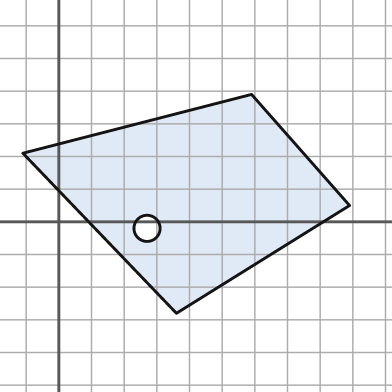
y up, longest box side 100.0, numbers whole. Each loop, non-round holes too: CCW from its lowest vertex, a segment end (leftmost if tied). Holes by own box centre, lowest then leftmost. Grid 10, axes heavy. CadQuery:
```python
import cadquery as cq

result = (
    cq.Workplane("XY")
    .moveTo(36.0, -28.0)
    .lineTo(89.0, 5.0)
    .lineTo(59.0, 39.0)
    .lineTo(-11.0, 21.0)
    .close()
    .moveTo(27.0, -2.0)
    .circle(4.0)
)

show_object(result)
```